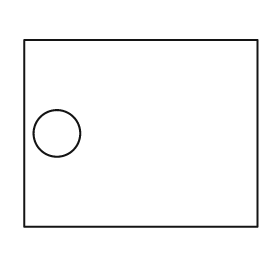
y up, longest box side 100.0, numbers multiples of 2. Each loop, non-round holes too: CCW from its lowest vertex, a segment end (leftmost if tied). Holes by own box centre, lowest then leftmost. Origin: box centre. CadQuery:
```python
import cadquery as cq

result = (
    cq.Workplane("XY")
    .moveTo(-50.0, -40.0)
    .lineTo(50.0, -40.0)
    .lineTo(50.0, 40.0)
    .lineTo(-50.0, 40.0)
    .close()
    .moveTo(-36.0, 0.0)
    .circle(10.0)
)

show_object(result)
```